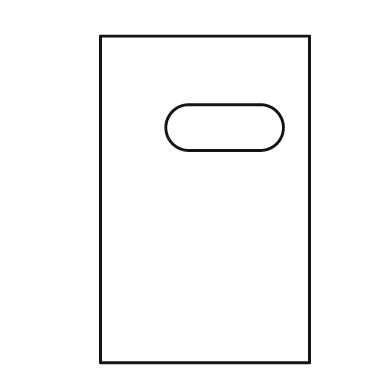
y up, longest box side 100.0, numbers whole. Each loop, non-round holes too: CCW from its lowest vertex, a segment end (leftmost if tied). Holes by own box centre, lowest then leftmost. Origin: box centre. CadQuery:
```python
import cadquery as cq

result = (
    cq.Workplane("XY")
    .moveTo(-32.0, -50.0)
    .lineTo(32.0, -50.0)
    .lineTo(32.0, 50.0)
    .lineTo(-32.0, 50.0)
    .close()
    .moveTo(-5.0, 15.0)
    .lineTo(17.0, 15.0)
    .threePointArc((24.0, 22.0), (17.0, 29.0))
    .lineTo(-5.0, 29.0)
    .threePointArc((-12.0, 22.0), (-5.0, 15.0))
    .close()
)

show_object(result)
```